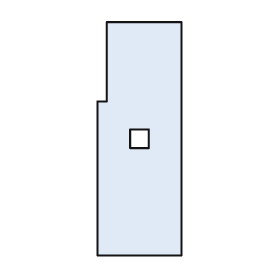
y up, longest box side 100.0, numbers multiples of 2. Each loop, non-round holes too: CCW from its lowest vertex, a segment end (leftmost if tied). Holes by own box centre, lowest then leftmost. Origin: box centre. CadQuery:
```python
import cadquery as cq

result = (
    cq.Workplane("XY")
    .moveTo(-18.0, -50.0)
    .lineTo(18.0, -50.0)
    .lineTo(18.0, 50.0)
    .lineTo(-14.0, 50.0)
    .lineTo(-14.0, 16.0)
    .lineTo(-18.0, 16.0)
    .close()
    .moveTo(-4.0, -4.0)
    .lineTo(4.0, -4.0)
    .lineTo(4.0, 4.0)
    .lineTo(-4.0, 4.0)
    .close()
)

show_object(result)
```